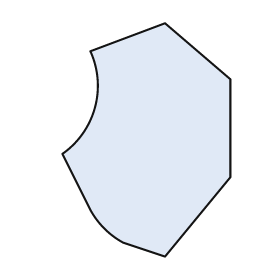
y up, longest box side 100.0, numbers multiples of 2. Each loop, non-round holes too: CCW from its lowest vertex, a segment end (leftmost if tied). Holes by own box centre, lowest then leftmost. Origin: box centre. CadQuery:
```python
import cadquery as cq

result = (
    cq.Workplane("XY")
    .moveTo(8.0, -50.0)
    .lineTo(36.0, -16.0)
    .lineTo(36.0, 26.0)
    .lineTo(8.0, 50.0)
    .lineTo(-24.0, 38.0)
    .threePointArc((-22.0, 14.0), (-36.0, -6.0))
    .lineTo(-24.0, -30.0)
    .threePointArc((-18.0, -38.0), (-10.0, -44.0))
    .close()
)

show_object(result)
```